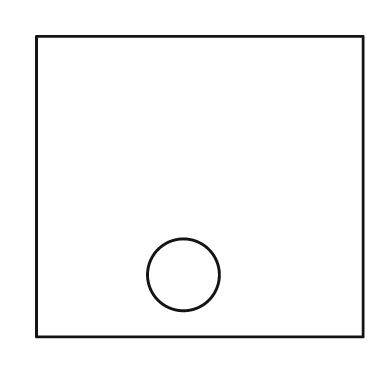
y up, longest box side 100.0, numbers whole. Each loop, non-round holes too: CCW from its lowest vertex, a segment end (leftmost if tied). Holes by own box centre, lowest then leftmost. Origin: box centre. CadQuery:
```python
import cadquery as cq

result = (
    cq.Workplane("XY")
    .moveTo(-50.0, -46.0)
    .lineTo(50.0, -46.0)
    .lineTo(50.0, 46.0)
    .lineTo(-50.0, 46.0)
    .close()
    .moveTo(-5.0, -27.0)
    .circle(11.0)
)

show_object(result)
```